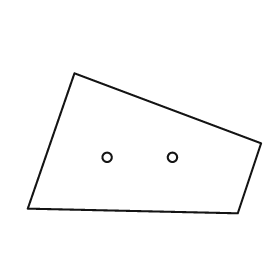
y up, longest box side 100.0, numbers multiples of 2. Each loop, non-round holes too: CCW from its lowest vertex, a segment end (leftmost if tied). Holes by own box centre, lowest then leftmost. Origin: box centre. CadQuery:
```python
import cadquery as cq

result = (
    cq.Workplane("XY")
    .moveTo(40.0, -30.0)
    .lineTo(50.0, 0.0)
    .lineTo(-30.0, 30.0)
    .lineTo(-50.0, -28.0)
    .close()
    .moveTo(-16.0, -6.0)
    .circle(2.0)
    .moveTo(12.0, -6.0)
    .circle(2.0)
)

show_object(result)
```